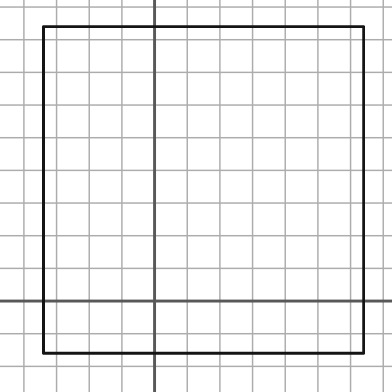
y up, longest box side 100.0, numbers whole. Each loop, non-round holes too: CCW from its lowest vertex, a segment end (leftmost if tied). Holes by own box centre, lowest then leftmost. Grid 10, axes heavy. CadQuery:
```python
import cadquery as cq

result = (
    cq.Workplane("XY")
    .moveTo(-34.0, -16.0)
    .lineTo(64.0, -16.0)
    .lineTo(64.0, 84.0)
    .lineTo(-34.0, 84.0)
    .close()
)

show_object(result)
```